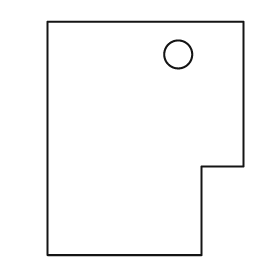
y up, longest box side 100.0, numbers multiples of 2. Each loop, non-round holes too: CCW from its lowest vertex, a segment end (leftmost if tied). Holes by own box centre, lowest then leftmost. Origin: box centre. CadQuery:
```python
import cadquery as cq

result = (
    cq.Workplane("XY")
    .moveTo(-42.0, -50.0)
    .lineTo(24.0, -50.0)
    .lineTo(24.0, -12.0)
    .lineTo(42.0, -12.0)
    .lineTo(42.0, 50.0)
    .lineTo(-42.0, 50.0)
    .close()
    .moveTo(14.0, 36.0)
    .circle(6.0)
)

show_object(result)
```